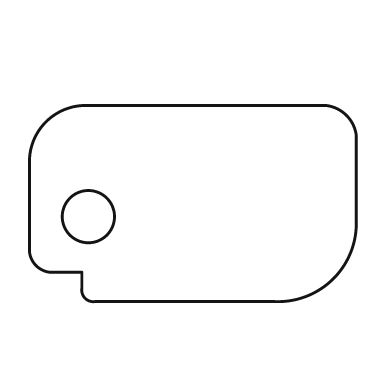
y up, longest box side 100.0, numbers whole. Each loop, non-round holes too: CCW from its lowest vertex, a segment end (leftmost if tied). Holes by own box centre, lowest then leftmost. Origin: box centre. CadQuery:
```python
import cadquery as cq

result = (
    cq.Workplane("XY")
    .moveTo(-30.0, -30.0)
    .lineTo(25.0, -30.0)
    .threePointArc((43.0, -23.0), (50.0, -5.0))
    .lineTo(50.0, 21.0)
    .threePointArc((47.0, 27.0), (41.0, 30.0))
    .lineTo(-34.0, 30.0)
    .threePointArc((-45.0, 25.0), (-50.0, 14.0))
    .lineTo(-50.0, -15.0)
    .threePointArc((-48.0, -19.0), (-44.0, -21.0))
    .lineTo(-34.0, -21.0)
    .lineTo(-34.0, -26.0)
    .threePointArc((-33.0, -29.0), (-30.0, -30.0))
    .close()
    .moveTo(-32.0, -4.0)
    .circle(8.0)
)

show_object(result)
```